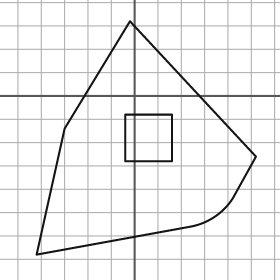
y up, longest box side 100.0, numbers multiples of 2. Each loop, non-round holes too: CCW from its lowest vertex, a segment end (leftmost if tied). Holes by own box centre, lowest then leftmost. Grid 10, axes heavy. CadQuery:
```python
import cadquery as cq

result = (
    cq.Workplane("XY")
    .moveTo(-42.0, -68.0)
    .lineTo(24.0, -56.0)
    .threePointArc((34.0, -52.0), (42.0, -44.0))
    .lineTo(52.0, -26.0)
    .lineTo(-2.0, 32.0)
    .lineTo(-30.0, -14.0)
    .close()
    .moveTo(-4.0, -28.0)
    .lineTo(16.0, -28.0)
    .lineTo(16.0, -8.0)
    .lineTo(-4.0, -8.0)
    .close()
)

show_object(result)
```